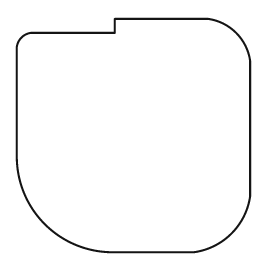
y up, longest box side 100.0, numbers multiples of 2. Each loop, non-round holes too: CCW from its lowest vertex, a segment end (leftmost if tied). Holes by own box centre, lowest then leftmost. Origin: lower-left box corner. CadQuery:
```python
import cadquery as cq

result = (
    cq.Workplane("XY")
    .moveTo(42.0, 0.0)
    .lineTo(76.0, 0.0)
    .threePointArc((92.0, 8.0), (100.0, 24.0))
    .lineTo(100.0, 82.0)
    .threePointArc((94.0, 94.0), (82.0, 100.0))
    .lineTo(42.0, 100.0)
    .lineTo(42.0, 94.0)
    .lineTo(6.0, 94.0)
    .threePointArc((2.0, 92.0), (0.0, 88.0))
    .lineTo(0.0, 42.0)
    .threePointArc((12.0, 12.0), (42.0, 0.0))
    .close()
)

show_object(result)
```